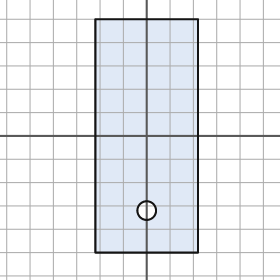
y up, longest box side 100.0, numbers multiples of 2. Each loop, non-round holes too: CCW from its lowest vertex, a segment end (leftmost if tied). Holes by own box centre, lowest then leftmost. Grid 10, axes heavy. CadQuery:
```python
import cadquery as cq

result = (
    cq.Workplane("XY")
    .moveTo(-22.0, -50.0)
    .lineTo(22.0, -50.0)
    .lineTo(22.0, 50.0)
    .lineTo(-22.0, 50.0)
    .close()
    .moveTo(0.0, -32.0)
    .circle(4.0)
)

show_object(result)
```